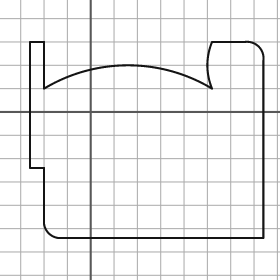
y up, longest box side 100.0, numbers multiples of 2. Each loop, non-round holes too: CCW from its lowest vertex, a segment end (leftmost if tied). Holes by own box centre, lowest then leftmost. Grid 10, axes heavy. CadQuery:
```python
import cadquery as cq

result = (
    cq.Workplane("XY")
    .moveTo(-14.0, -54.0)
    .lineTo(74.0, -54.0)
    .lineTo(74.0, 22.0)
    .threePointArc((72.0, 28.0), (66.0, 30.0))
    .lineTo(52.0, 30.0)
    .threePointArc((50.0, 20.0), (52.0, 10.0))
    .threePointArc((16.0, 20.0), (-20.0, 10.0))
    .lineTo(-20.0, 30.0)
    .lineTo(-26.0, 30.0)
    .lineTo(-26.0, -24.0)
    .lineTo(-20.0, -24.0)
    .lineTo(-20.0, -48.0)
    .threePointArc((-18.0, -52.0), (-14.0, -54.0))
    .close()
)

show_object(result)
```